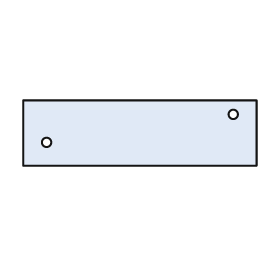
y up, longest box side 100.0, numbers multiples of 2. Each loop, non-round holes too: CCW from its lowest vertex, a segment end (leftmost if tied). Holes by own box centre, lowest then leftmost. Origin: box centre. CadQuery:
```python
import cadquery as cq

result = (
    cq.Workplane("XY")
    .moveTo(-50.0, -14.0)
    .lineTo(50.0, -14.0)
    .lineTo(50.0, 14.0)
    .lineTo(-50.0, 14.0)
    .close()
    .moveTo(-40.0, -4.0)
    .circle(2.0)
    .moveTo(40.0, 8.0)
    .circle(2.0)
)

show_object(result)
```